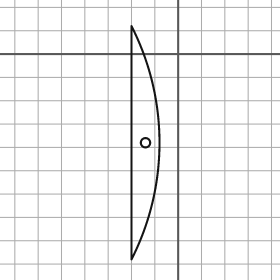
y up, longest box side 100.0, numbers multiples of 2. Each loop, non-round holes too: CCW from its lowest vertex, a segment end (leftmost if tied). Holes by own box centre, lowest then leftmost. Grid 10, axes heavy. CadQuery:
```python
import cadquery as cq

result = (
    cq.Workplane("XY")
    .moveTo(-20.0, -88.0)
    .threePointArc((-8.0, -38.0), (-20.0, 12.0))
    .close()
    .moveTo(-14.0, -38.0)
    .circle(2.0)
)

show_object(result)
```